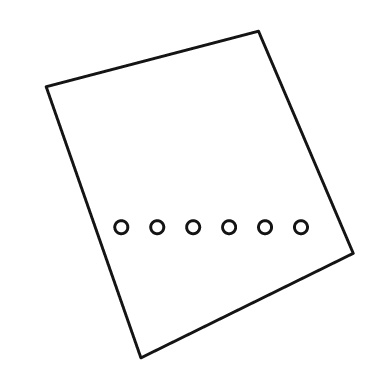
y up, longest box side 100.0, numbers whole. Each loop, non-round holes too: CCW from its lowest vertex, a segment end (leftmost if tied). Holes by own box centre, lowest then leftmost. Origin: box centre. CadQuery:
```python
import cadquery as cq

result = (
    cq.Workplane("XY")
    .moveTo(-18.0, -50.0)
    .lineTo(47.0, -18.0)
    .lineTo(18.0, 50.0)
    .lineTo(-47.0, 33.0)
    .close()
    .moveTo(-24.0, -10.0)
    .circle(2.0)
    .moveTo(-13.0, -10.0)
    .circle(2.0)
    .moveTo(-2.0, -10.0)
    .circle(2.0)
    .moveTo(9.0, -10.0)
    .circle(2.0)
    .moveTo(20.0, -10.0)
    .circle(2.0)
    .moveTo(31.0, -10.0)
    .circle(2.0)
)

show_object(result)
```